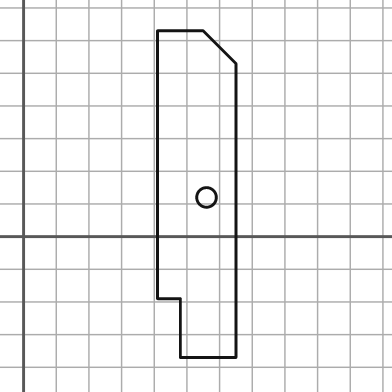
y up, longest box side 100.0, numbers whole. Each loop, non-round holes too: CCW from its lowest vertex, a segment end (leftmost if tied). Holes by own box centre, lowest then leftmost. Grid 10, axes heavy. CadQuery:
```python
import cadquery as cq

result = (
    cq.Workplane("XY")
    .moveTo(48.0, -37.0)
    .lineTo(65.0, -37.0)
    .lineTo(65.0, 53.0)
    .lineTo(55.0, 63.0)
    .lineTo(41.0, 63.0)
    .lineTo(41.0, -19.0)
    .lineTo(48.0, -19.0)
    .close()
    .moveTo(56.0, 12.0)
    .circle(3.0)
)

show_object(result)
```